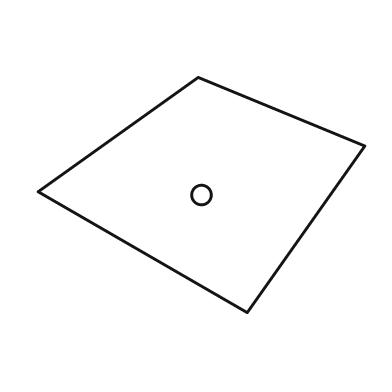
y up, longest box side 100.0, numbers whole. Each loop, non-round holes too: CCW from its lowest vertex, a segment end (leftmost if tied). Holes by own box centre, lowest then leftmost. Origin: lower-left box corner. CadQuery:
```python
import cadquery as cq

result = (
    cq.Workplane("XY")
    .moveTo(64.0, 0.0)
    .lineTo(100.0, 51.0)
    .lineTo(49.0, 72.0)
    .lineTo(0.0, 37.0)
    .close()
    .moveTo(50.0, 36.0)
    .circle(3.0)
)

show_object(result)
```